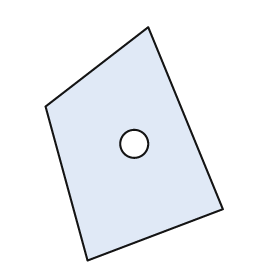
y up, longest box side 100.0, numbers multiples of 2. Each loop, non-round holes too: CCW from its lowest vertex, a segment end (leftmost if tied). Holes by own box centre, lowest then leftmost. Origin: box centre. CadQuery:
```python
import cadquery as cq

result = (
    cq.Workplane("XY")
    .moveTo(-20.0, -50.0)
    .lineTo(38.0, -28.0)
    .lineTo(6.0, 50.0)
    .lineTo(-38.0, 16.0)
    .close()
    .moveTo(0.0, 0.0)
    .circle(6.0)
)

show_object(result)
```